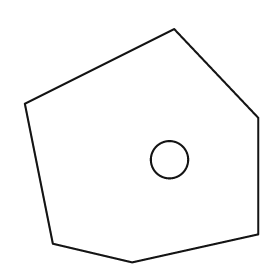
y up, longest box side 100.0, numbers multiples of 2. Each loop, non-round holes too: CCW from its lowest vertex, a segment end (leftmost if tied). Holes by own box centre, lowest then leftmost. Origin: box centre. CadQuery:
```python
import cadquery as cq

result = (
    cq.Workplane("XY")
    .moveTo(-4.0, -50.0)
    .lineTo(50.0, -38.0)
    .lineTo(50.0, 12.0)
    .lineTo(14.0, 50.0)
    .lineTo(-50.0, 18.0)
    .lineTo(-38.0, -42.0)
    .close()
    .moveTo(12.0, -6.0)
    .circle(8.0)
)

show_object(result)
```